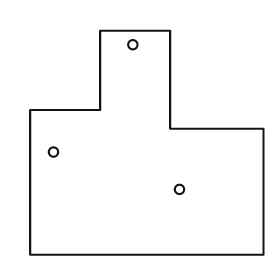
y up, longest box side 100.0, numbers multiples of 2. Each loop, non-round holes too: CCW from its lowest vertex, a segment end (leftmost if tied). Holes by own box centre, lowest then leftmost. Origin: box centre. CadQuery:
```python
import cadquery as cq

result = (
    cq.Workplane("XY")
    .moveTo(-50.0, -48.0)
    .lineTo(50.0, -48.0)
    .lineTo(50.0, 6.0)
    .lineTo(10.0, 6.0)
    .lineTo(10.0, 48.0)
    .lineTo(-20.0, 48.0)
    .lineTo(-20.0, 14.0)
    .lineTo(-50.0, 14.0)
    .close()
    .moveTo(14.0, -20.0)
    .circle(2.0)
    .moveTo(-40.0, -4.0)
    .circle(2.0)
    .moveTo(-6.0, 42.0)
    .circle(2.0)
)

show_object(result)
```